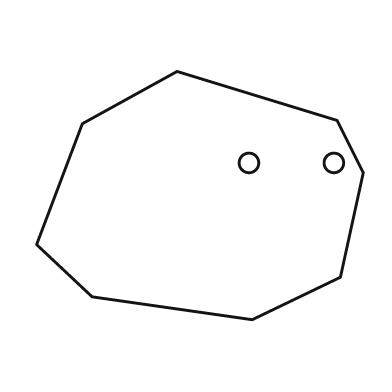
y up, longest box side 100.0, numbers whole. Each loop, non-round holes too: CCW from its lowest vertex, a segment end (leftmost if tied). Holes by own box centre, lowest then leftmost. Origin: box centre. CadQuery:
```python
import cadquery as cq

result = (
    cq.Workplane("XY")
    .moveTo(16.0, -38.0)
    .lineTo(43.0, -25.0)
    .lineTo(50.0, 7.0)
    .lineTo(42.0, 23.0)
    .lineTo(-7.0, 38.0)
    .lineTo(-36.0, 22.0)
    .lineTo(-50.0, -15.0)
    .lineTo(-33.0, -31.0)
    .close()
    .moveTo(15.0, 10.0)
    .circle(3.0)
    .moveTo(41.0, 10.0)
    .circle(3.0)
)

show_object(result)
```